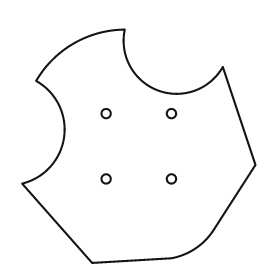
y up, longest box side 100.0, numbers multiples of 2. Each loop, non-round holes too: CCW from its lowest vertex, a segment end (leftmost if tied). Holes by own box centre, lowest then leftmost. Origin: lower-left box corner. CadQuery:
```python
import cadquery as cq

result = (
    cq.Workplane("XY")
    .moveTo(30.0, 0.0)
    .lineTo(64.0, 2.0)
    .threePointArc((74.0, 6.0), (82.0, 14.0))
    .lineTo(100.0, 42.0)
    .lineTo(86.0, 84.0)
    .threePointArc((58.0, 74.0), (44.0, 100.0))
    .threePointArc((22.0, 94.0), (6.0, 78.0))
    .threePointArc((18.0, 54.0), (0.0, 34.0))
    .close()
    .moveTo(36.0, 36.0)
    .circle(2.0)
    .moveTo(64.0, 36.0)
    .circle(2.0)
    .moveTo(36.0, 64.0)
    .circle(2.0)
    .moveTo(64.0, 64.0)
    .circle(2.0)
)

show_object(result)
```